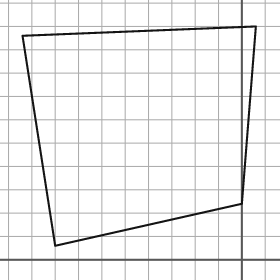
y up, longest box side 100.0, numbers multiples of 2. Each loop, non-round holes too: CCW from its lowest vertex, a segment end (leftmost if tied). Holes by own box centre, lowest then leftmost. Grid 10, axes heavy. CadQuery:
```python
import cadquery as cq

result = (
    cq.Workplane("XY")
    .moveTo(-80.0, 6.0)
    .lineTo(0.0, 24.0)
    .lineTo(6.0, 100.0)
    .lineTo(-94.0, 96.0)
    .close()
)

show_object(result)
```